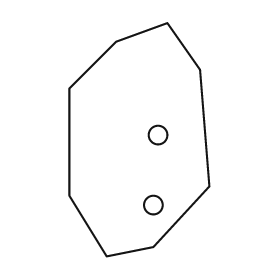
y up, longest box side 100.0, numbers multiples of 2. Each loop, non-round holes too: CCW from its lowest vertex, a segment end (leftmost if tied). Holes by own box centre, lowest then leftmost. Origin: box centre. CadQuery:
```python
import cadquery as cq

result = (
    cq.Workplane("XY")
    .moveTo(-14.0, -50.0)
    .lineTo(6.0, -46.0)
    .lineTo(30.0, -20.0)
    .lineTo(26.0, 30.0)
    .lineTo(12.0, 50.0)
    .lineTo(-10.0, 42.0)
    .lineTo(-30.0, 22.0)
    .lineTo(-30.0, -24.0)
    .close()
    .moveTo(6.0, -28.0)
    .circle(4.0)
    .moveTo(8.0, 2.0)
    .circle(4.0)
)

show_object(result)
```